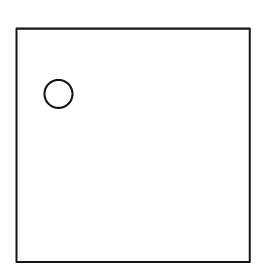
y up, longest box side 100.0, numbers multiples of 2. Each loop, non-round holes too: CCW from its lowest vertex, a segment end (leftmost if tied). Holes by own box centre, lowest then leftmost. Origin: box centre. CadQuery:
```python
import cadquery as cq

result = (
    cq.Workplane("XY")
    .moveTo(-50.0, -50.0)
    .lineTo(50.0, -50.0)
    .lineTo(50.0, 50.0)
    .lineTo(-50.0, 50.0)
    .close()
    .moveTo(-32.0, 22.0)
    .circle(6.0)
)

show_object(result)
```